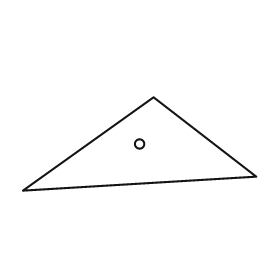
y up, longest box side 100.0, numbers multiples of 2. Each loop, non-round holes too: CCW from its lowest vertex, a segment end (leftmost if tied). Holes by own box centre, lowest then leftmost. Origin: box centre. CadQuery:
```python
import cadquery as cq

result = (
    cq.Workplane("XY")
    .moveTo(-50.0, -20.0)
    .lineTo(50.0, -14.0)
    .lineTo(6.0, 20.0)
    .close()
    .moveTo(0.0, 0.0)
    .circle(2.0)
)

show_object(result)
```